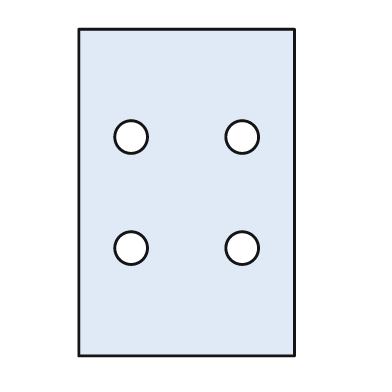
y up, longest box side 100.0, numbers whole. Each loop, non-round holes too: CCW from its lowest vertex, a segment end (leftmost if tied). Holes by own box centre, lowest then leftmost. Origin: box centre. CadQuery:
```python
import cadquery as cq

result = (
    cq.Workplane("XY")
    .moveTo(-33.0, -50.0)
    .lineTo(33.0, -50.0)
    .lineTo(33.0, 50.0)
    .lineTo(-33.0, 50.0)
    .close()
    .moveTo(-17.0, -17.0)
    .circle(5.0)
    .moveTo(17.0, -17.0)
    .circle(5.0)
    .moveTo(-17.0, 17.0)
    .circle(5.0)
    .moveTo(17.0, 17.0)
    .circle(5.0)
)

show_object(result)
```